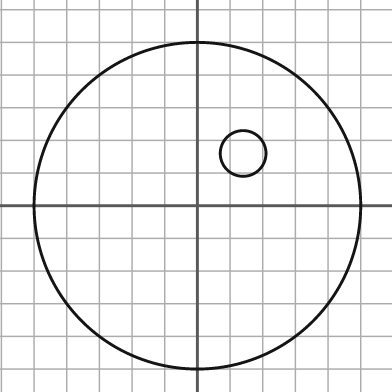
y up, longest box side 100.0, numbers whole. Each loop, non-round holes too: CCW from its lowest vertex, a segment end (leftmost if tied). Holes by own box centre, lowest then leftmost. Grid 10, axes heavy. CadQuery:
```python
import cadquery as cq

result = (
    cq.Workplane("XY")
    .moveTo(0.0, 0.0)
    .circle(50.0)
    .moveTo(14.0, 16.0)
    .circle(7.0)
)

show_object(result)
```